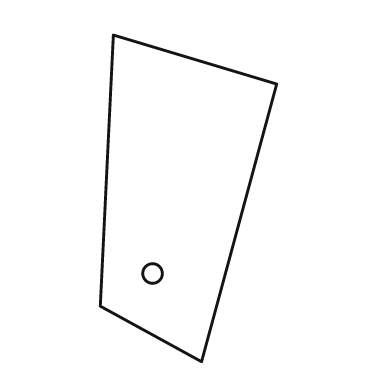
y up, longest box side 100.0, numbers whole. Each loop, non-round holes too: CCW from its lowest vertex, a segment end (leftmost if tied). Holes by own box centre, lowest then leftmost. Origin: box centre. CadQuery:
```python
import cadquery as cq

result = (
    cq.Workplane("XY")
    .moveTo(4.0, -50.0)
    .lineTo(27.0, 35.0)
    .lineTo(-23.0, 50.0)
    .lineTo(-27.0, -33.0)
    .close()
    .moveTo(-11.0, -23.0)
    .circle(3.0)
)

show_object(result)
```